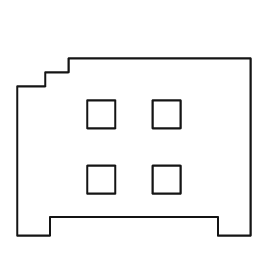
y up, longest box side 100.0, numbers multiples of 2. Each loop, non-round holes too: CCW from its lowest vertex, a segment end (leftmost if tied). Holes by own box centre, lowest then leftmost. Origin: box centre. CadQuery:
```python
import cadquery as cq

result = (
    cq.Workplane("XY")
    .moveTo(-50.0, -38.0)
    .lineTo(-36.0, -38.0)
    .lineTo(-36.0, -30.0)
    .lineTo(36.0, -30.0)
    .lineTo(36.0, -38.0)
    .lineTo(50.0, -38.0)
    .lineTo(50.0, 38.0)
    .lineTo(-28.0, 38.0)
    .lineTo(-28.0, 32.0)
    .lineTo(-38.0, 32.0)
    .lineTo(-38.0, 26.0)
    .lineTo(-50.0, 26.0)
    .close()
    .moveTo(-20.0, -20.0)
    .lineTo(-8.0, -20.0)
    .lineTo(-8.0, -8.0)
    .lineTo(-20.0, -8.0)
    .close()
    .moveTo(8.0, -20.0)
    .lineTo(20.0, -20.0)
    .lineTo(20.0, -8.0)
    .lineTo(8.0, -8.0)
    .close()
    .moveTo(-20.0, 8.0)
    .lineTo(-8.0, 8.0)
    .lineTo(-8.0, 20.0)
    .lineTo(-20.0, 20.0)
    .close()
    .moveTo(8.0, 8.0)
    .lineTo(20.0, 8.0)
    .lineTo(20.0, 20.0)
    .lineTo(8.0, 20.0)
    .close()
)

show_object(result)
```